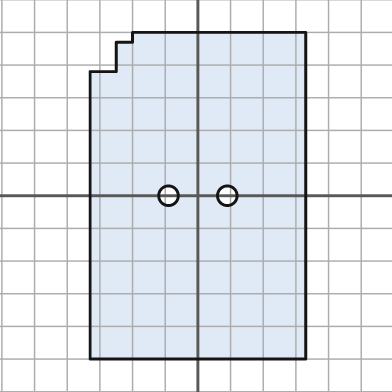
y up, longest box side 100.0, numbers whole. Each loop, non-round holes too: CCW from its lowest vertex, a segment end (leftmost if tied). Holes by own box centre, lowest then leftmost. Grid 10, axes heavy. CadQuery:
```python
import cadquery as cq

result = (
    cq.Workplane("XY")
    .moveTo(-33.0, -50.0)
    .lineTo(33.0, -50.0)
    .lineTo(33.0, 50.0)
    .lineTo(-20.0, 50.0)
    .lineTo(-20.0, 47.0)
    .lineTo(-25.0, 47.0)
    .lineTo(-25.0, 38.0)
    .lineTo(-33.0, 38.0)
    .close()
    .moveTo(-9.0, 0.0)
    .circle(3.0)
    .moveTo(9.0, 0.0)
    .circle(3.0)
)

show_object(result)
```